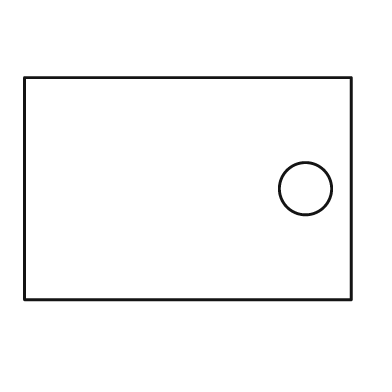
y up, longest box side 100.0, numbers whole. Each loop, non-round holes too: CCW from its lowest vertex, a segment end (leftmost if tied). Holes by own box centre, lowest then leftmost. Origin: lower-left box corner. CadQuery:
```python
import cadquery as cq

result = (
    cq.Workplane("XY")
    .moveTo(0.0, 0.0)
    .lineTo(100.0, 0.0)
    .lineTo(100.0, 68.0)
    .lineTo(0.0, 68.0)
    .close()
    .moveTo(86.0, 34.0)
    .circle(8.0)
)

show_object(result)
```